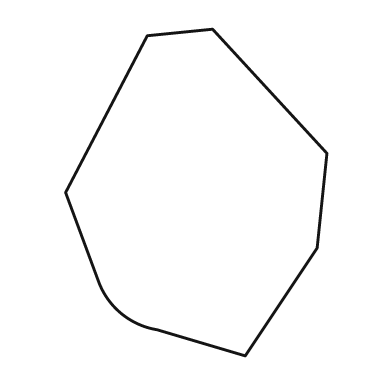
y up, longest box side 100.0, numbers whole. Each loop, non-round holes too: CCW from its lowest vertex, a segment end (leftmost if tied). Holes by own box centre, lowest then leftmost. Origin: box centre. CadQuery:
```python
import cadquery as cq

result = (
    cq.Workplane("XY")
    .moveTo(15.0, -50.0)
    .lineTo(37.0, -17.0)
    .lineTo(40.0, 12.0)
    .lineTo(5.0, 50.0)
    .lineTo(-15.0, 48.0)
    .lineTo(-40.0, 0.0)
    .lineTo(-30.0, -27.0)
    .threePointArc((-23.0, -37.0), (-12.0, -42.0))
    .close()
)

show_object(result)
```